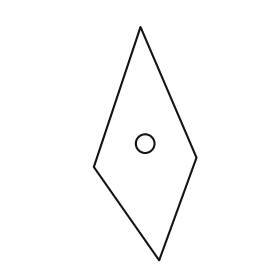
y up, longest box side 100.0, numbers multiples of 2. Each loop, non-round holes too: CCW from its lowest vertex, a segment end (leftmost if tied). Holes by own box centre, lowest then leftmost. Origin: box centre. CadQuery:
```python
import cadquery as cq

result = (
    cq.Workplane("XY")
    .moveTo(6.0, -50.0)
    .lineTo(22.0, -6.0)
    .lineTo(-2.0, 50.0)
    .lineTo(-22.0, -10.0)
    .close()
    .moveTo(0.0, 0.0)
    .circle(4.0)
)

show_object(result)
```